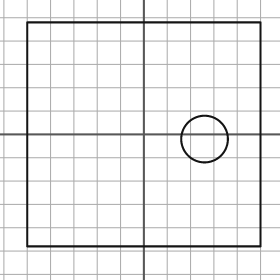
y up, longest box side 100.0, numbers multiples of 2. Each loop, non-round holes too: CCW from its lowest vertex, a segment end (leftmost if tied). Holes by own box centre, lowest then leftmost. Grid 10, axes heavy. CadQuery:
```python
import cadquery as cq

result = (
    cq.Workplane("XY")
    .moveTo(-50.0, -48.0)
    .lineTo(50.0, -48.0)
    .lineTo(50.0, 48.0)
    .lineTo(-50.0, 48.0)
    .close()
    .moveTo(26.0, -2.0)
    .circle(10.0)
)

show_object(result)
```